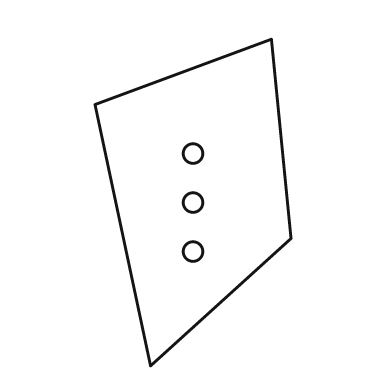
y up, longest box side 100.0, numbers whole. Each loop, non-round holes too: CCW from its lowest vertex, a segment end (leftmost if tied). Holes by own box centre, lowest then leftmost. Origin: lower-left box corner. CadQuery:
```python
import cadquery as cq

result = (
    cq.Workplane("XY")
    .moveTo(17.0, 0.0)
    .lineTo(60.0, 39.0)
    .lineTo(54.0, 100.0)
    .lineTo(0.0, 80.0)
    .close()
    .moveTo(30.0, 35.0)
    .circle(3.0)
    .moveTo(30.0, 50.0)
    .circle(3.0)
    .moveTo(30.0, 65.0)
    .circle(3.0)
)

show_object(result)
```